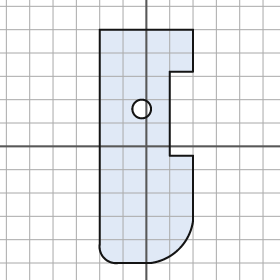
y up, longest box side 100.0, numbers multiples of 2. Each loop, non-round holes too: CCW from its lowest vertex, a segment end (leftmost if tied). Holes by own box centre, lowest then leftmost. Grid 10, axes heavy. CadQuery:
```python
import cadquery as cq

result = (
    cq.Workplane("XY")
    .moveTo(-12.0, -50.0)
    .lineTo(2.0, -50.0)
    .threePointArc((14.0, -44.0), (20.0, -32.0))
    .lineTo(20.0, -4.0)
    .lineTo(10.0, -4.0)
    .lineTo(10.0, 32.0)
    .lineTo(20.0, 32.0)
    .lineTo(20.0, 50.0)
    .lineTo(-20.0, 50.0)
    .lineTo(-20.0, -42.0)
    .threePointArc((-18.0, -48.0), (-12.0, -50.0))
    .close()
    .moveTo(-2.0, 16.0)
    .circle(4.0)
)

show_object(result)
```